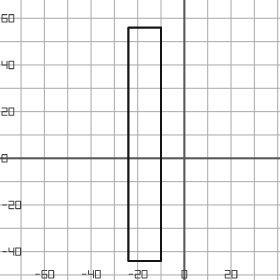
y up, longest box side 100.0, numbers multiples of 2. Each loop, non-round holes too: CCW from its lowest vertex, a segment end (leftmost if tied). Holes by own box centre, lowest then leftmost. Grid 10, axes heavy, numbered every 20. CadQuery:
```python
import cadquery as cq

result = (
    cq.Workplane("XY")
    .moveTo(-24.0, -44.0)
    .lineTo(-10.0, -44.0)
    .lineTo(-10.0, 56.0)
    .lineTo(-24.0, 56.0)
    .close()
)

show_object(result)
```